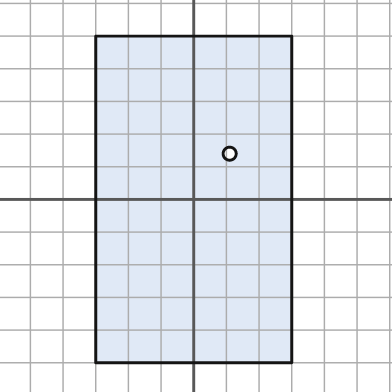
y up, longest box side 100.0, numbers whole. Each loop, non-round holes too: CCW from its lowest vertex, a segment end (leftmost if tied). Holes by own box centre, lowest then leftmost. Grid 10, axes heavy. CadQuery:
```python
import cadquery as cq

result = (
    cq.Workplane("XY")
    .moveTo(-30.0, -50.0)
    .lineTo(30.0, -50.0)
    .lineTo(30.0, 50.0)
    .lineTo(-30.0, 50.0)
    .close()
    .moveTo(11.0, 14.0)
    .circle(2.0)
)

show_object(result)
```